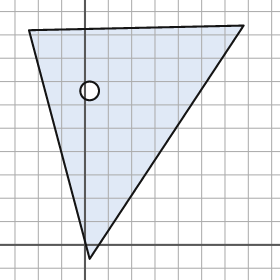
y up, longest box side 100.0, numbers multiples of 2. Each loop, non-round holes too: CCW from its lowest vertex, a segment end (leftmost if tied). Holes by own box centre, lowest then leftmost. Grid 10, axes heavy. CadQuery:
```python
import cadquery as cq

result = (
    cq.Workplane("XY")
    .moveTo(2.0, -6.0)
    .lineTo(68.0, 94.0)
    .lineTo(-24.0, 92.0)
    .close()
    .moveTo(2.0, 66.0)
    .circle(4.0)
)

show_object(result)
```